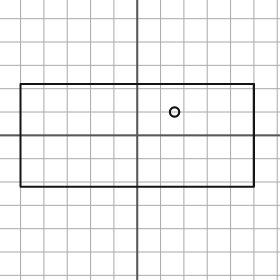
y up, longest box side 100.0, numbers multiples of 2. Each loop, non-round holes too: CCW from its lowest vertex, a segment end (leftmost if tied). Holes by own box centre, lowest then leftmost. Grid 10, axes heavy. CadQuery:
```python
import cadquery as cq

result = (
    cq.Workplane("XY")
    .moveTo(-50.0, -22.0)
    .lineTo(50.0, -22.0)
    .lineTo(50.0, 22.0)
    .lineTo(-50.0, 22.0)
    .close()
    .moveTo(16.0, 10.0)
    .circle(2.0)
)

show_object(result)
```